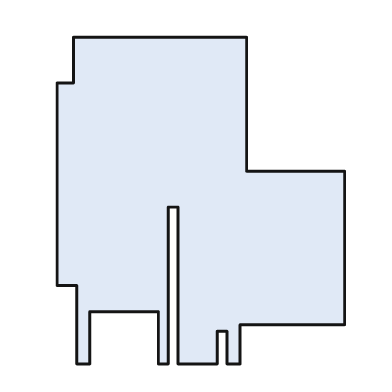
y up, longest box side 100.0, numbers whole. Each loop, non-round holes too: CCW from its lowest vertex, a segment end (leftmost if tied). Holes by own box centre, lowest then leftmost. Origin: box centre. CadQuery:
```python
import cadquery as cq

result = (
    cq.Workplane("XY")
    .moveTo(-38.0, -50.0)
    .lineTo(-34.0, -50.0)
    .lineTo(-34.0, -34.0)
    .lineTo(-13.0, -34.0)
    .lineTo(-13.0, -50.0)
    .lineTo(-10.0, -50.0)
    .lineTo(-10.0, -2.0)
    .lineTo(-7.0, -2.0)
    .lineTo(-7.0, -50.0)
    .lineTo(5.0, -50.0)
    .lineTo(5.0, -40.0)
    .lineTo(8.0, -40.0)
    .lineTo(8.0, -50.0)
    .lineTo(12.0, -50.0)
    .lineTo(12.0, -38.0)
    .lineTo(44.0, -38.0)
    .lineTo(44.0, 9.0)
    .lineTo(14.0, 9.0)
    .lineTo(14.0, 50.0)
    .lineTo(-39.0, 50.0)
    .lineTo(-39.0, 36.0)
    .lineTo(-44.0, 36.0)
    .lineTo(-44.0, -26.0)
    .lineTo(-38.0, -26.0)
    .close()
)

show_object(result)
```